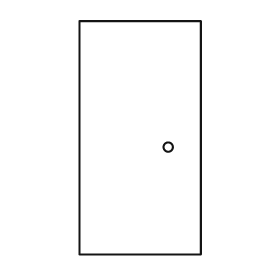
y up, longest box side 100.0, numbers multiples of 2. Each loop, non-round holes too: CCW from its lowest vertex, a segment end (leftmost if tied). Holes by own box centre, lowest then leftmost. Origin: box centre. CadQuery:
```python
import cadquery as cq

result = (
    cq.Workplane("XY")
    .moveTo(-26.0, -50.0)
    .lineTo(26.0, -50.0)
    .lineTo(26.0, 50.0)
    .lineTo(-26.0, 50.0)
    .close()
    .moveTo(12.0, -4.0)
    .circle(2.0)
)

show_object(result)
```